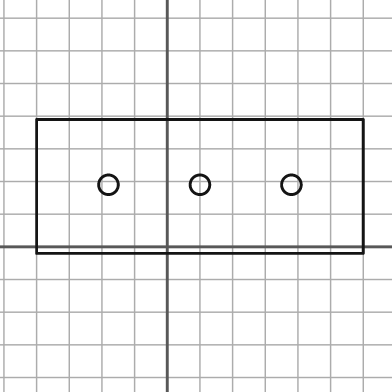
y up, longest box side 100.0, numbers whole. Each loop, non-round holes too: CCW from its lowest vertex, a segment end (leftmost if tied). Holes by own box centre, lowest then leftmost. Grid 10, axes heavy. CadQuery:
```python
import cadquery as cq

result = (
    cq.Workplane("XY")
    .moveTo(-40.0, -2.0)
    .lineTo(60.0, -2.0)
    .lineTo(60.0, 39.0)
    .lineTo(-40.0, 39.0)
    .close()
    .moveTo(-18.0, 19.0)
    .circle(3.0)
    .moveTo(10.0, 19.0)
    .circle(3.0)
    .moveTo(38.0, 19.0)
    .circle(3.0)
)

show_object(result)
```